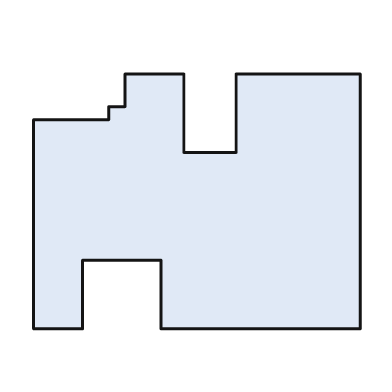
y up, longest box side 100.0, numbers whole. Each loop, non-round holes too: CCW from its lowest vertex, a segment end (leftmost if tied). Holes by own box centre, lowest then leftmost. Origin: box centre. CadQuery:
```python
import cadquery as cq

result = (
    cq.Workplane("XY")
    .moveTo(-50.0, -39.0)
    .lineTo(-35.0, -39.0)
    .lineTo(-35.0, -18.0)
    .lineTo(-11.0, -18.0)
    .lineTo(-11.0, -39.0)
    .lineTo(50.0, -39.0)
    .lineTo(50.0, 39.0)
    .lineTo(12.0, 39.0)
    .lineTo(12.0, 15.0)
    .lineTo(-4.0, 15.0)
    .lineTo(-4.0, 39.0)
    .lineTo(-22.0, 39.0)
    .lineTo(-22.0, 29.0)
    .lineTo(-27.0, 29.0)
    .lineTo(-27.0, 25.0)
    .lineTo(-50.0, 25.0)
    .close()
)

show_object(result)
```